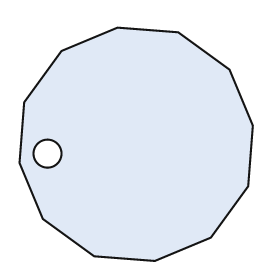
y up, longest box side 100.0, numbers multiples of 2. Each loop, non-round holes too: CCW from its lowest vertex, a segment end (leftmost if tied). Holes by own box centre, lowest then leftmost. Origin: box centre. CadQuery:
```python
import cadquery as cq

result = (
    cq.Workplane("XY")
    .moveTo(8.0, -50.0)
    .lineTo(32.0, -40.0)
    .lineTo(48.0, -18.0)
    .lineTo(50.0, 8.0)
    .lineTo(40.0, 32.0)
    .lineTo(18.0, 48.0)
    .lineTo(-8.0, 50.0)
    .lineTo(-32.0, 40.0)
    .lineTo(-48.0, 18.0)
    .lineTo(-50.0, -8.0)
    .lineTo(-40.0, -32.0)
    .lineTo(-18.0, -48.0)
    .close()
    .moveTo(-38.0, -4.0)
    .circle(6.0)
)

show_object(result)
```